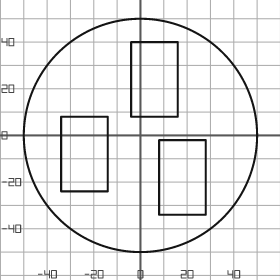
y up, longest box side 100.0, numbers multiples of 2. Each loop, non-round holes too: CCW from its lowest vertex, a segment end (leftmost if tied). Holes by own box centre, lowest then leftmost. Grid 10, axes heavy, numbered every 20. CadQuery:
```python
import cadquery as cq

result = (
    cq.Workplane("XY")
    .moveTo(0.0, 0.0)
    .circle(50.0)
    .moveTo(8.0, -34.0)
    .lineTo(28.0, -34.0)
    .lineTo(28.0, -2.0)
    .lineTo(8.0, -2.0)
    .close()
    .moveTo(-34.0, -24.0)
    .lineTo(-14.0, -24.0)
    .lineTo(-14.0, 8.0)
    .lineTo(-34.0, 8.0)
    .close()
    .moveTo(-4.0, 8.0)
    .lineTo(16.0, 8.0)
    .lineTo(16.0, 40.0)
    .lineTo(-4.0, 40.0)
    .close()
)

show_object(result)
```